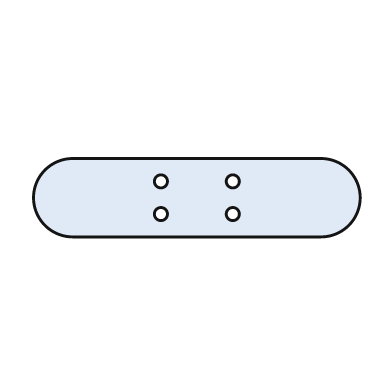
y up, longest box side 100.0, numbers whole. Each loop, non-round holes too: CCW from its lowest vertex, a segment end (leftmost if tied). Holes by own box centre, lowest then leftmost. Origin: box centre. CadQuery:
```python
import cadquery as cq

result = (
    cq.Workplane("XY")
    .moveTo(-38.0, -12.0)
    .lineTo(38.0, -12.0)
    .threePointArc((50.0, 0.0), (38.0, 12.0))
    .lineTo(-38.0, 12.0)
    .threePointArc((-50.0, 0.0), (-38.0, -12.0))
    .close()
    .moveTo(-11.0, -5.0)
    .circle(2.0)
    .moveTo(11.0, -5.0)
    .circle(2.0)
    .moveTo(-11.0, 5.0)
    .circle(2.0)
    .moveTo(11.0, 5.0)
    .circle(2.0)
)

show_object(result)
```